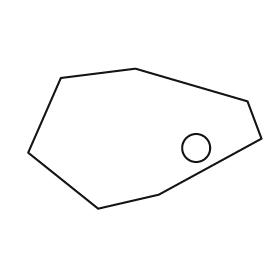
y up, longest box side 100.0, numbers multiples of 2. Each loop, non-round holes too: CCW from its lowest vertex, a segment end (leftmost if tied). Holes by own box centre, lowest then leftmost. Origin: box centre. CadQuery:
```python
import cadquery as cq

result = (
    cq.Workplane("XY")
    .moveTo(-20.0, -30.0)
    .lineTo(6.0, -24.0)
    .lineTo(50.0, 0.0)
    .lineTo(44.0, 16.0)
    .lineTo(-4.0, 30.0)
    .lineTo(-36.0, 26.0)
    .lineTo(-50.0, -6.0)
    .close()
    .moveTo(22.0, -4.0)
    .circle(6.0)
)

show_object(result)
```